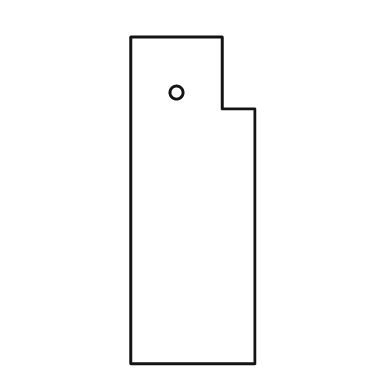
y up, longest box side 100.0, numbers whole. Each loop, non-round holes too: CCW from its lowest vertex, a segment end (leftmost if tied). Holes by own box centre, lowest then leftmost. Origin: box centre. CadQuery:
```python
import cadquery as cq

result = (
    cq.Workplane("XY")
    .moveTo(-19.0, -50.0)
    .lineTo(19.0, -50.0)
    .lineTo(19.0, 28.0)
    .lineTo(9.0, 28.0)
    .lineTo(9.0, 50.0)
    .lineTo(-19.0, 50.0)
    .close()
    .moveTo(-5.0, 33.0)
    .circle(2.0)
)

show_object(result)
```